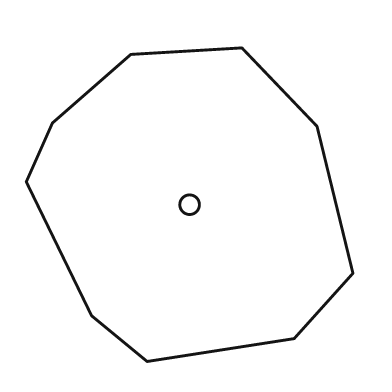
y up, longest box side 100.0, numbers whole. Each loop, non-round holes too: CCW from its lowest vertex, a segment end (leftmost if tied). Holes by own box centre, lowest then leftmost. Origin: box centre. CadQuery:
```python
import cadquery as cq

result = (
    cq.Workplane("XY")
    .moveTo(-13.0, -48.0)
    .lineTo(32.0, -41.0)
    .lineTo(50.0, -21.0)
    .lineTo(39.0, 24.0)
    .lineTo(16.0, 48.0)
    .lineTo(-18.0, 46.0)
    .lineTo(-42.0, 25.0)
    .lineTo(-50.0, 7.0)
    .lineTo(-30.0, -34.0)
    .close()
    .moveTo(0.0, 0.0)
    .circle(3.0)
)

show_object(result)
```